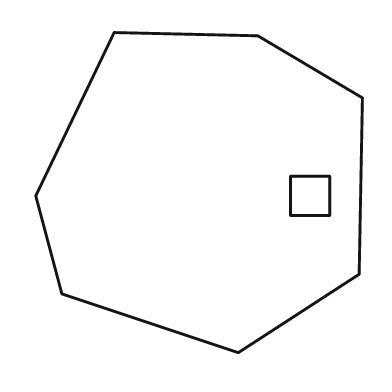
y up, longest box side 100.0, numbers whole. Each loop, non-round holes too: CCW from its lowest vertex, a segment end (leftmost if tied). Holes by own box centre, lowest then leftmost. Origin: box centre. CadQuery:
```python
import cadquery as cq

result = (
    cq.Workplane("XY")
    .moveTo(12.0, -49.0)
    .lineTo(49.0, -25.0)
    .lineTo(50.0, 29.0)
    .lineTo(18.0, 48.0)
    .lineTo(-26.0, 49.0)
    .lineTo(-50.0, -1.0)
    .lineTo(-42.0, -31.0)
    .close()
    .moveTo(28.0, -7.0)
    .lineTo(40.0, -7.0)
    .lineTo(40.0, 5.0)
    .lineTo(28.0, 5.0)
    .close()
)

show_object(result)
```